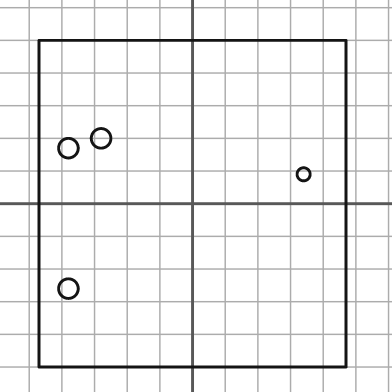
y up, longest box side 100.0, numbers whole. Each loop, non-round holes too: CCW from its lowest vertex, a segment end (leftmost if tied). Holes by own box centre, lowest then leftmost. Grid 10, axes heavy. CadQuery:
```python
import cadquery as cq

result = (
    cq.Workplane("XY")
    .moveTo(-47.0, -50.0)
    .lineTo(47.0, -50.0)
    .lineTo(47.0, 50.0)
    .lineTo(-47.0, 50.0)
    .close()
    .moveTo(-38.0, -26.0)
    .circle(3.0)
    .moveTo(34.0, 9.0)
    .circle(2.0)
    .moveTo(-38.0, 17.0)
    .circle(3.0)
    .moveTo(-28.0, 20.0)
    .circle(3.0)
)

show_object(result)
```